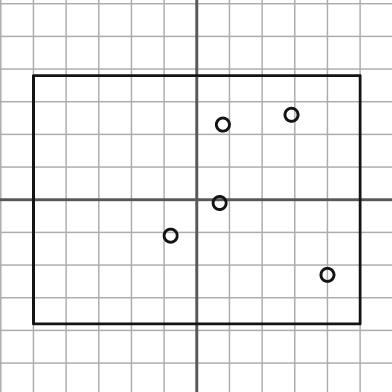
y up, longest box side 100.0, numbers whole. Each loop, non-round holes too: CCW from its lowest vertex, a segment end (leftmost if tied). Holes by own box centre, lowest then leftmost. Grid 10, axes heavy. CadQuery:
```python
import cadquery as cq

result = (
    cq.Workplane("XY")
    .moveTo(-50.0, -38.0)
    .lineTo(50.0, -38.0)
    .lineTo(50.0, 38.0)
    .lineTo(-50.0, 38.0)
    .close()
    .moveTo(40.0, -23.0)
    .circle(2.0)
    .moveTo(-8.0, -11.0)
    .circle(2.0)
    .moveTo(7.0, -1.0)
    .circle(2.0)
    .moveTo(8.0, 23.0)
    .circle(2.0)
    .moveTo(29.0, 26.0)
    .circle(2.0)
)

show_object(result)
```